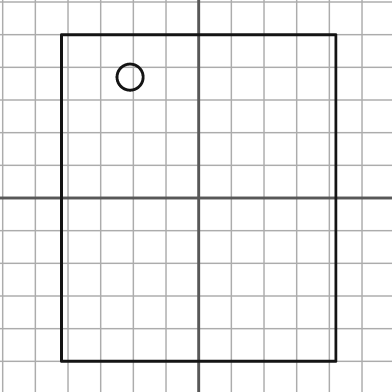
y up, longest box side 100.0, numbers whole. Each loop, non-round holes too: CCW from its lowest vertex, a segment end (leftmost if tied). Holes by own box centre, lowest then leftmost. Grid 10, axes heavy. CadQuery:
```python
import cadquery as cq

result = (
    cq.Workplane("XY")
    .moveTo(-42.0, -50.0)
    .lineTo(42.0, -50.0)
    .lineTo(42.0, 50.0)
    .lineTo(-42.0, 50.0)
    .close()
    .moveTo(-21.0, 37.0)
    .circle(4.0)
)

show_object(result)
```